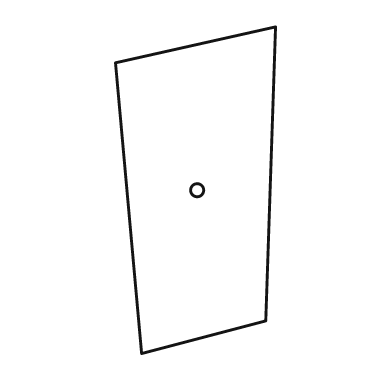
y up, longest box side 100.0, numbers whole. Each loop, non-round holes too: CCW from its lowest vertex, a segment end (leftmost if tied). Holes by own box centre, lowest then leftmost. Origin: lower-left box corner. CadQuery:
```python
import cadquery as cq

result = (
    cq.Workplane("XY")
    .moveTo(8.0, 0.0)
    .lineTo(46.0, 10.0)
    .lineTo(49.0, 100.0)
    .lineTo(0.0, 89.0)
    .close()
    .moveTo(25.0, 50.0)
    .circle(2.0)
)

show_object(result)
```